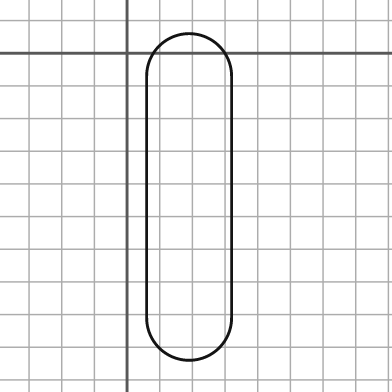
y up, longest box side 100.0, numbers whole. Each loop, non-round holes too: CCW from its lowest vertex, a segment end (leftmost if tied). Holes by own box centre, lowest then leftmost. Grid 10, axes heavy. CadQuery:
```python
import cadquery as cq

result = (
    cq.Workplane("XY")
    .moveTo(6.0, -81.0)
    .threePointArc((19.0, -94.0), (32.0, -81.0))
    .lineTo(32.0, -7.0)
    .threePointArc((19.0, 6.0), (6.0, -7.0))
    .close()
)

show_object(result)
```